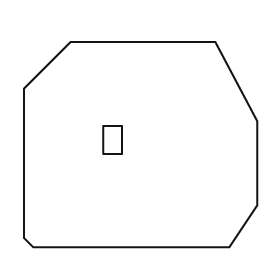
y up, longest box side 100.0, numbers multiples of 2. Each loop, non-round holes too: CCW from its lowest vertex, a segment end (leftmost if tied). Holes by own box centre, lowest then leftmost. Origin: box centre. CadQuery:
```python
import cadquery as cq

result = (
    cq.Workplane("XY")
    .moveTo(-46.0, -44.0)
    .lineTo(38.0, -44.0)
    .lineTo(50.0, -26.0)
    .lineTo(50.0, 10.0)
    .lineTo(32.0, 44.0)
    .lineTo(-30.0, 44.0)
    .lineTo(-50.0, 24.0)
    .lineTo(-50.0, -40.0)
    .close()
    .moveTo(-16.0, -4.0)
    .lineTo(-8.0, -4.0)
    .lineTo(-8.0, 8.0)
    .lineTo(-16.0, 8.0)
    .close()
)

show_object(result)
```